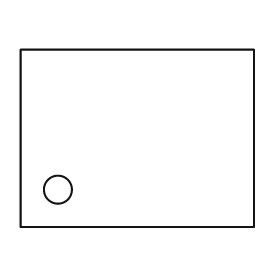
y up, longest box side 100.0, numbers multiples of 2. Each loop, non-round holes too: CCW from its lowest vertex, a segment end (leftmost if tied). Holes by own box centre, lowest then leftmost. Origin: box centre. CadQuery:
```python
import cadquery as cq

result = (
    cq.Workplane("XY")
    .moveTo(-50.0, -38.0)
    .lineTo(50.0, -38.0)
    .lineTo(50.0, 38.0)
    .lineTo(-50.0, 38.0)
    .close()
    .moveTo(-34.0, -22.0)
    .circle(6.0)
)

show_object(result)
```